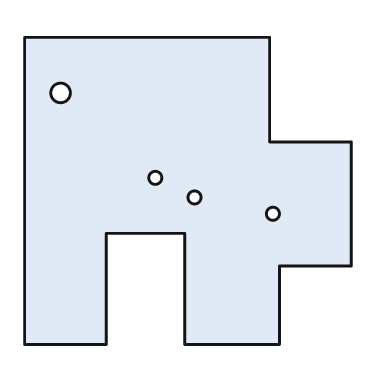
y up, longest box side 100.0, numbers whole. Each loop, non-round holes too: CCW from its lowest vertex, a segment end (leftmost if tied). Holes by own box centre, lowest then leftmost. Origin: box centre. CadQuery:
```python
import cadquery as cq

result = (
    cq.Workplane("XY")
    .moveTo(-50.0, -47.0)
    .lineTo(-25.0, -47.0)
    .lineTo(-25.0, -13.0)
    .lineTo(-1.0, -13.0)
    .lineTo(-1.0, -47.0)
    .lineTo(28.0, -47.0)
    .lineTo(28.0, -23.0)
    .lineTo(50.0, -23.0)
    .lineTo(50.0, 15.0)
    .lineTo(25.0, 15.0)
    .lineTo(25.0, 47.0)
    .lineTo(-50.0, 47.0)
    .close()
    .moveTo(26.0, -7.0)
    .circle(2.0)
    .moveTo(2.0, -2.0)
    .circle(2.0)
    .moveTo(-10.0, 4.0)
    .circle(2.0)
    .moveTo(-39.0, 30.0)
    .circle(3.0)
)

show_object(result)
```